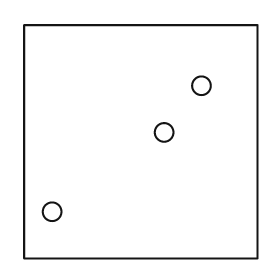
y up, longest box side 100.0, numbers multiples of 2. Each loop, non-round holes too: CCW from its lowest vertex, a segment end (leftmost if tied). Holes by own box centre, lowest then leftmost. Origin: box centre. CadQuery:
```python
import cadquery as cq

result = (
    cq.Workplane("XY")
    .moveTo(-50.0, -50.0)
    .lineTo(50.0, -50.0)
    .lineTo(50.0, 50.0)
    .lineTo(-50.0, 50.0)
    .close()
    .moveTo(-38.0, -30.0)
    .circle(4.0)
    .moveTo(10.0, 4.0)
    .circle(4.0)
    .moveTo(26.0, 24.0)
    .circle(4.0)
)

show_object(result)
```